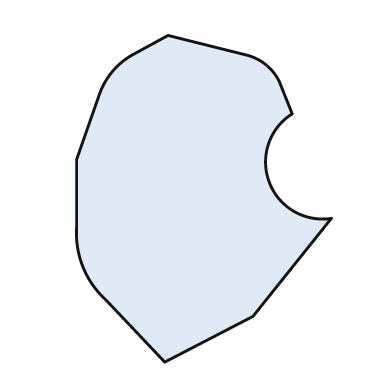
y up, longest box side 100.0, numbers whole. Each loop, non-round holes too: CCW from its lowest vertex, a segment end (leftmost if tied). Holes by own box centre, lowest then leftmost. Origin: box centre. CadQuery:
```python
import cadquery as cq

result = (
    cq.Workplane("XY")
    .moveTo(-12.0, -50.0)
    .lineTo(15.0, -36.0)
    .lineTo(39.0, -6.0)
    .threePointArc((20.0, 5.0), (27.0, 26.0))
    .lineTo(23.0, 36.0)
    .threePointArc((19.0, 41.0), (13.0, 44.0))
    .lineTo(-11.0, 50.0)
    .lineTo(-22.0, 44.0)
    .threePointArc((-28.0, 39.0), (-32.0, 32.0))
    .lineTo(-39.0, 12.0)
    .lineTo(-39.0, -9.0)
    .threePointArc((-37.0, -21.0), (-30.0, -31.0))
    .close()
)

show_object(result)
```